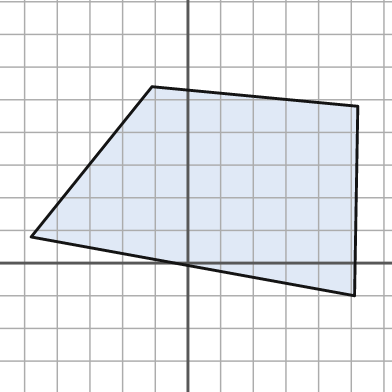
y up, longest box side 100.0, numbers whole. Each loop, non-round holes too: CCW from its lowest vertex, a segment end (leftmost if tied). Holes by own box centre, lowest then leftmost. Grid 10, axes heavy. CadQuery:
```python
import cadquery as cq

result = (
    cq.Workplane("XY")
    .moveTo(51.0, -10.0)
    .lineTo(52.0, 48.0)
    .lineTo(-11.0, 54.0)
    .lineTo(-48.0, 8.0)
    .close()
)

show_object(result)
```